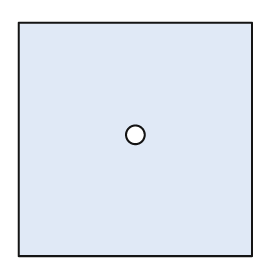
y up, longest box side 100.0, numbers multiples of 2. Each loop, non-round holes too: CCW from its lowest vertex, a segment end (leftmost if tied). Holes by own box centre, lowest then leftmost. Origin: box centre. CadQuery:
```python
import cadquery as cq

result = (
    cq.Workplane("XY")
    .moveTo(-50.0, -50.0)
    .lineTo(50.0, -50.0)
    .lineTo(50.0, 50.0)
    .lineTo(-50.0, 50.0)
    .close()
    .moveTo(0.0, 2.0)
    .circle(4.0)
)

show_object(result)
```